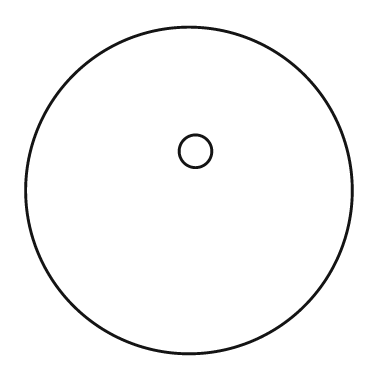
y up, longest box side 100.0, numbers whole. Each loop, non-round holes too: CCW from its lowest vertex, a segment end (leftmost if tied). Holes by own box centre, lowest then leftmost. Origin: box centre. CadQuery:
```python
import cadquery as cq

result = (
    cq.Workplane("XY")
    .moveTo(0.0, 0.0)
    .circle(50.0)
    .moveTo(2.0, 12.0)
    .circle(5.0)
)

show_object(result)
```